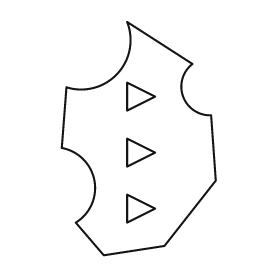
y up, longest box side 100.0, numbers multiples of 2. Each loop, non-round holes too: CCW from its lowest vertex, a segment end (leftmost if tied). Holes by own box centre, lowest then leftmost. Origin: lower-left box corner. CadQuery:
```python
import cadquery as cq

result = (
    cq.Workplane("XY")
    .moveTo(18.0, 0.0)
    .lineTo(44.0, 4.0)
    .lineTo(66.0, 32.0)
    .lineTo(64.0, 60.0)
    .threePointArc((52.0, 68.0), (56.0, 82.0))
    .lineTo(28.0, 100.0)
    .threePointArc((24.0, 78.0), (2.0, 72.0))
    .lineTo(0.0, 46.0)
    .threePointArc((14.0, 32.0), (6.0, 14.0))
    .close()
    .moveTo(28.0, 14.0)
    .lineTo(40.0, 20.0)
    .lineTo(28.0, 26.0)
    .close()
    .moveTo(28.0, 38.0)
    .lineTo(40.0, 44.0)
    .lineTo(28.0, 50.0)
    .close()
    .moveTo(28.0, 62.0)
    .lineTo(40.0, 68.0)
    .lineTo(28.0, 74.0)
    .close()
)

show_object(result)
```